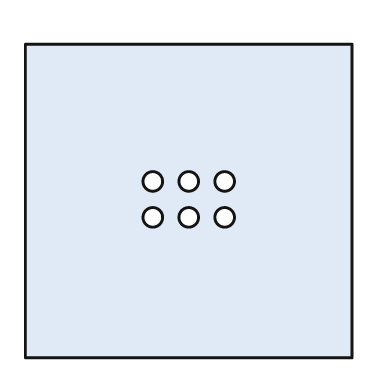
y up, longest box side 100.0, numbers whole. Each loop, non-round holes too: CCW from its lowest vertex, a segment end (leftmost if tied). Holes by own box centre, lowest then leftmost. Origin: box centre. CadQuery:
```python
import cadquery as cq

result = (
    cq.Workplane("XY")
    .moveTo(-50.0, -48.0)
    .lineTo(50.0, -48.0)
    .lineTo(50.0, 48.0)
    .lineTo(-50.0, 48.0)
    .close()
    .moveTo(-11.0, -5.0)
    .circle(3.0)
    .moveTo(0.0, -5.0)
    .circle(3.0)
    .moveTo(11.0, -5.0)
    .circle(3.0)
    .moveTo(-11.0, 6.0)
    .circle(3.0)
    .moveTo(0.0, 6.0)
    .circle(3.0)
    .moveTo(11.0, 6.0)
    .circle(3.0)
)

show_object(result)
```